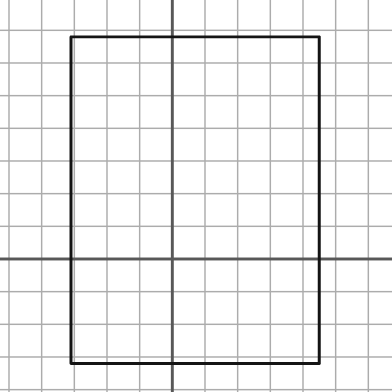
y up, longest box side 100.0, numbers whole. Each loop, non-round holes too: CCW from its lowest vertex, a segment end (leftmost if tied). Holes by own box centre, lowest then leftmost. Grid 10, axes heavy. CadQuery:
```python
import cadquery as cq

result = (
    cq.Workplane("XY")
    .moveTo(-31.0, -32.0)
    .lineTo(45.0, -32.0)
    .lineTo(45.0, 68.0)
    .lineTo(-31.0, 68.0)
    .close()
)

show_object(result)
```